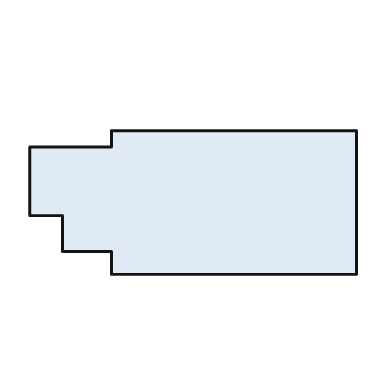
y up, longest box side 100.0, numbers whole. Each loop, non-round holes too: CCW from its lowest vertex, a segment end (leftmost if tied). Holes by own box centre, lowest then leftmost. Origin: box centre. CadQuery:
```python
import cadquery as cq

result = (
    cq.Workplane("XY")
    .moveTo(-25.0, -22.0)
    .lineTo(50.0, -22.0)
    .lineTo(50.0, 22.0)
    .lineTo(-25.0, 22.0)
    .lineTo(-25.0, 17.0)
    .lineTo(-50.0, 17.0)
    .lineTo(-50.0, -4.0)
    .lineTo(-40.0, -4.0)
    .lineTo(-40.0, -15.0)
    .lineTo(-25.0, -15.0)
    .close()
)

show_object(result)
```